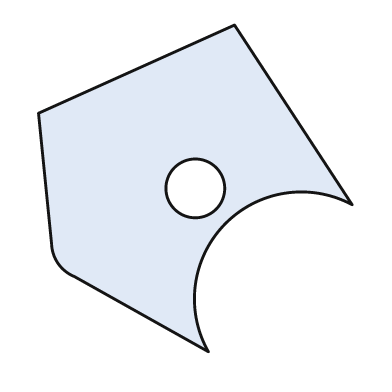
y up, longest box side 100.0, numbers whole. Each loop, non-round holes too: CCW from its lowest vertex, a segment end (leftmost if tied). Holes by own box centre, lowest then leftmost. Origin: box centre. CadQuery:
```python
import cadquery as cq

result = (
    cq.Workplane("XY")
    .moveTo(4.0, -50.0)
    .threePointArc((9.0, -11.0), (48.0, -5.0))
    .lineTo(12.0, 50.0)
    .lineTo(-48.0, 23.0)
    .lineTo(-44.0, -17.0)
    .threePointArc((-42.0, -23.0), (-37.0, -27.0))
    .close()
    .moveTo(0.0, 0.0)
    .circle(9.0)
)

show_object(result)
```